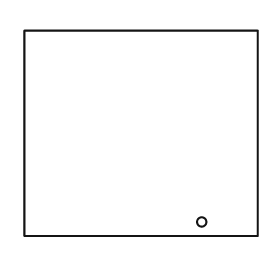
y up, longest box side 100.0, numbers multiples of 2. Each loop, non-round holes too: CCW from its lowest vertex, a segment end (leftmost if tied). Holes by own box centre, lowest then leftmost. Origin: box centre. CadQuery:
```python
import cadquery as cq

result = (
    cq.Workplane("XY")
    .moveTo(-50.0, -44.0)
    .lineTo(50.0, -44.0)
    .lineTo(50.0, 44.0)
    .lineTo(-50.0, 44.0)
    .close()
    .moveTo(26.0, -38.0)
    .circle(2.0)
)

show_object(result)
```